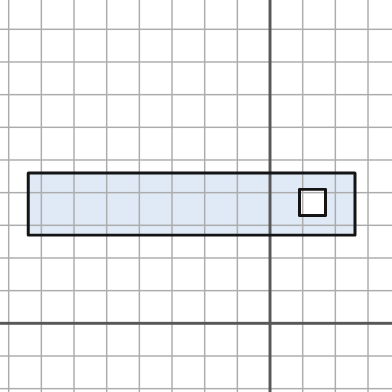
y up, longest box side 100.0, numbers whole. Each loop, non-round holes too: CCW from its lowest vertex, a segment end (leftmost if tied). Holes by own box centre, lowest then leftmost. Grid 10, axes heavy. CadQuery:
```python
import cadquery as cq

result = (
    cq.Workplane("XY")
    .moveTo(-74.0, 27.0)
    .lineTo(26.0, 27.0)
    .lineTo(26.0, 46.0)
    .lineTo(-74.0, 46.0)
    .close()
    .moveTo(9.0, 33.0)
    .lineTo(17.0, 33.0)
    .lineTo(17.0, 41.0)
    .lineTo(9.0, 41.0)
    .close()
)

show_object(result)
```